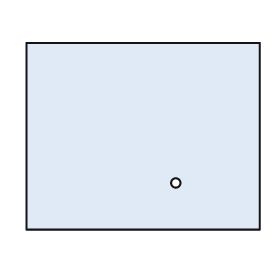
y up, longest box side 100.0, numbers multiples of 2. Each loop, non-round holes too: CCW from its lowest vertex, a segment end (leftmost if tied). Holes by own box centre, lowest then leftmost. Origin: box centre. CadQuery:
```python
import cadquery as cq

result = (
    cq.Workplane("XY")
    .moveTo(-50.0, -40.0)
    .lineTo(50.0, -40.0)
    .lineTo(50.0, 40.0)
    .lineTo(-50.0, 40.0)
    .close()
    .moveTo(14.0, -20.0)
    .circle(2.0)
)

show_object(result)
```